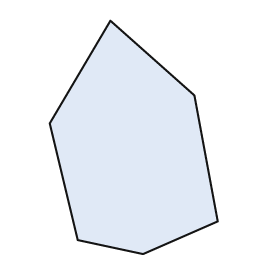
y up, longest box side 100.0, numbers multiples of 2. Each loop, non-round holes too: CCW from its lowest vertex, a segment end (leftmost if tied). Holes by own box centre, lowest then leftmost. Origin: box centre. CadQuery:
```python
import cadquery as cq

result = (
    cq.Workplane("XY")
    .moveTo(4.0, -50.0)
    .lineTo(36.0, -36.0)
    .lineTo(26.0, 18.0)
    .lineTo(-10.0, 50.0)
    .lineTo(-36.0, 6.0)
    .lineTo(-24.0, -44.0)
    .close()
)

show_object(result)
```